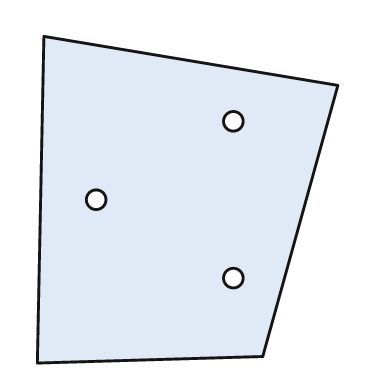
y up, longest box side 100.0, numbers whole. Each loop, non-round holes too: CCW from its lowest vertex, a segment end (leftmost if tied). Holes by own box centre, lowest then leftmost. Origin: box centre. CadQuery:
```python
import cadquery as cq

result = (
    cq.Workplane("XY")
    .moveTo(-46.0, -50.0)
    .lineTo(23.0, -48.0)
    .lineTo(46.0, 35.0)
    .lineTo(-44.0, 50.0)
    .close()
    .moveTo(14.0, -24.0)
    .circle(3.0)
    .moveTo(-28.0, 0.0)
    .circle(3.0)
    .moveTo(14.0, 24.0)
    .circle(3.0)
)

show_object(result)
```